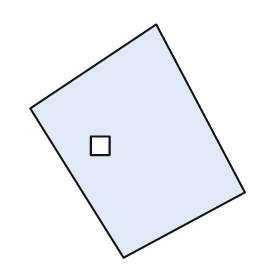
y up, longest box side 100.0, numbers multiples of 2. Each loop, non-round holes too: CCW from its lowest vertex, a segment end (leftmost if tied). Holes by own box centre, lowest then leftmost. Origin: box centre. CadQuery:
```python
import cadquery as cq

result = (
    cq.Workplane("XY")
    .moveTo(-6.0, -50.0)
    .lineTo(46.0, -22.0)
    .lineTo(8.0, 50.0)
    .lineTo(-46.0, 14.0)
    .close()
    .moveTo(-20.0, -6.0)
    .lineTo(-12.0, -6.0)
    .lineTo(-12.0, 2.0)
    .lineTo(-20.0, 2.0)
    .close()
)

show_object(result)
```